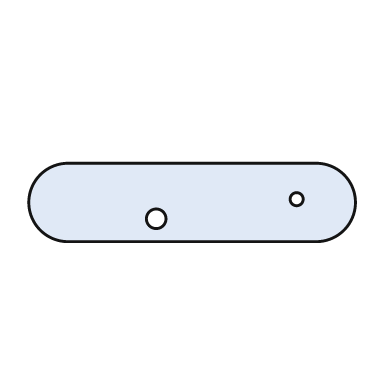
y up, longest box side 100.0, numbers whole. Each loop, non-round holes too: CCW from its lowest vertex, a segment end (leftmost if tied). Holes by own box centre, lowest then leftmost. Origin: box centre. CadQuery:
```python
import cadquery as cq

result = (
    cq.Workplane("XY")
    .moveTo(-38.0, -12.0)
    .lineTo(38.0, -12.0)
    .threePointArc((50.0, 0.0), (38.0, 12.0))
    .lineTo(-38.0, 12.0)
    .threePointArc((-50.0, 0.0), (-38.0, -12.0))
    .close()
    .moveTo(-11.0, -5.0)
    .circle(3.0)
    .moveTo(32.0, 1.0)
    .circle(2.0)
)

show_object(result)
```